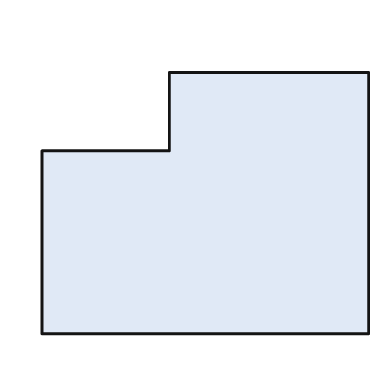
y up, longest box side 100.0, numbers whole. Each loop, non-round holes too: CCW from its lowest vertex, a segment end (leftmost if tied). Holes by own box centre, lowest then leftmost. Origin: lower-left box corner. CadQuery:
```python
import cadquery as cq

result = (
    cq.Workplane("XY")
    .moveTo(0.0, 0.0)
    .lineTo(100.0, 0.0)
    .lineTo(100.0, 80.0)
    .lineTo(39.0, 80.0)
    .lineTo(39.0, 56.0)
    .lineTo(0.0, 56.0)
    .close()
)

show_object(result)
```